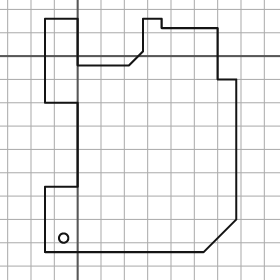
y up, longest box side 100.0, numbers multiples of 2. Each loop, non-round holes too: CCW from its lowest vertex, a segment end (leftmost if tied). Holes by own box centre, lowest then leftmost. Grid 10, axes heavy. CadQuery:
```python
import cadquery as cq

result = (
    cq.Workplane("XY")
    .moveTo(-14.0, -84.0)
    .lineTo(54.0, -84.0)
    .lineTo(68.0, -70.0)
    .lineTo(68.0, -10.0)
    .lineTo(60.0, -10.0)
    .lineTo(60.0, 12.0)
    .lineTo(36.0, 12.0)
    .lineTo(36.0, 16.0)
    .lineTo(28.0, 16.0)
    .lineTo(28.0, 2.0)
    .lineTo(22.0, -4.0)
    .lineTo(0.0, -4.0)
    .lineTo(0.0, 16.0)
    .lineTo(-14.0, 16.0)
    .lineTo(-14.0, -20.0)
    .lineTo(0.0, -20.0)
    .lineTo(0.0, -56.0)
    .lineTo(-14.0, -56.0)
    .close()
    .moveTo(-6.0, -78.0)
    .circle(2.0)
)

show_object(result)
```